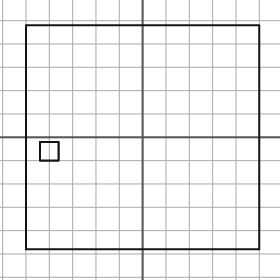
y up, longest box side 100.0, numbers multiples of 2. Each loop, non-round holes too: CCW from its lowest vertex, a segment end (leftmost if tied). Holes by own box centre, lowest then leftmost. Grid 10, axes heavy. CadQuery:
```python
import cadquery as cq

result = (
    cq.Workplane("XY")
    .moveTo(-50.0, -48.0)
    .lineTo(50.0, -48.0)
    .lineTo(50.0, 48.0)
    .lineTo(-50.0, 48.0)
    .close()
    .moveTo(-44.0, -10.0)
    .lineTo(-36.0, -10.0)
    .lineTo(-36.0, -2.0)
    .lineTo(-44.0, -2.0)
    .close()
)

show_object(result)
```